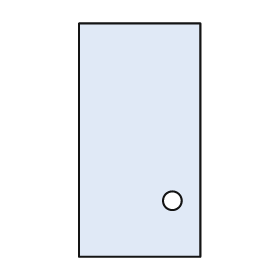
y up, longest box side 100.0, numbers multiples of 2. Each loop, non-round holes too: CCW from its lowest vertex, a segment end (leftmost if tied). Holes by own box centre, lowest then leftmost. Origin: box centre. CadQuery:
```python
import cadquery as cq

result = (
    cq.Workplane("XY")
    .moveTo(-26.0, -50.0)
    .lineTo(26.0, -50.0)
    .lineTo(26.0, 50.0)
    .lineTo(-26.0, 50.0)
    .close()
    .moveTo(14.0, -26.0)
    .circle(4.0)
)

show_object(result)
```